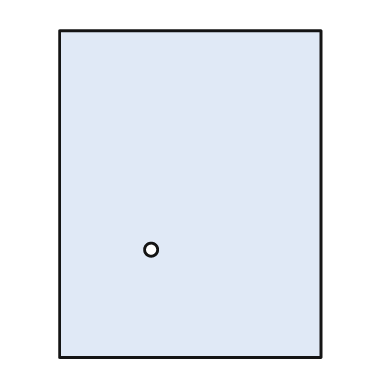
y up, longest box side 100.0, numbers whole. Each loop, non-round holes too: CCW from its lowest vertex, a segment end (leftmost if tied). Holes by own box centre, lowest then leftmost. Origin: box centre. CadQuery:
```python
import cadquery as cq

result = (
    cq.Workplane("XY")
    .moveTo(-40.0, -50.0)
    .lineTo(40.0, -50.0)
    .lineTo(40.0, 50.0)
    .lineTo(-40.0, 50.0)
    .close()
    .moveTo(-12.0, -17.0)
    .circle(2.0)
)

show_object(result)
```